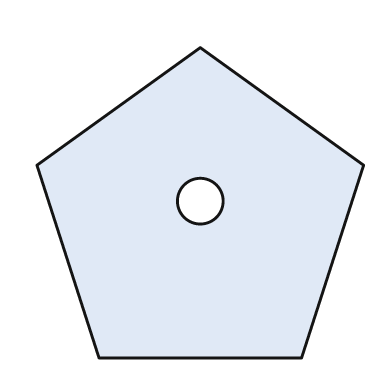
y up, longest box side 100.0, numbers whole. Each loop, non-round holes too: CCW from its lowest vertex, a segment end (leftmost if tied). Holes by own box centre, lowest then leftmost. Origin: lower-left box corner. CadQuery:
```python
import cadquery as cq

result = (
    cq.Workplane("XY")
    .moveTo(19.0, 0.0)
    .lineTo(81.0, 0.0)
    .lineTo(100.0, 59.0)
    .lineTo(50.0, 95.0)
    .lineTo(0.0, 59.0)
    .close()
    .moveTo(50.0, 48.0)
    .circle(7.0)
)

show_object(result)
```